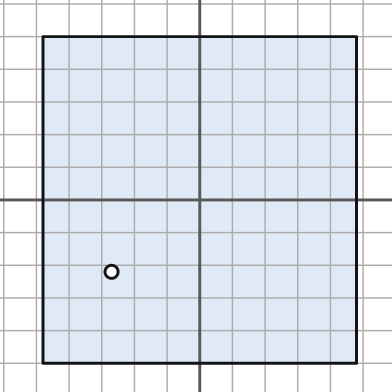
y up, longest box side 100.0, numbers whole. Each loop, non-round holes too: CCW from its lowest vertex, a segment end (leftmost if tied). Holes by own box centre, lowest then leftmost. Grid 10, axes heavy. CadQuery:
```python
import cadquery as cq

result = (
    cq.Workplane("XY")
    .moveTo(-48.0, -50.0)
    .lineTo(48.0, -50.0)
    .lineTo(48.0, 50.0)
    .lineTo(-48.0, 50.0)
    .close()
    .moveTo(-27.0, -22.0)
    .circle(2.0)
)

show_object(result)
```